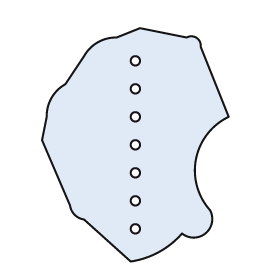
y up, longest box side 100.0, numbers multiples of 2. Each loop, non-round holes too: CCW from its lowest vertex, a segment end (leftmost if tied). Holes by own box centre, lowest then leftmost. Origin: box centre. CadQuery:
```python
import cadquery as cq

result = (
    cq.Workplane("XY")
    .moveTo(-2.0, -50.0)
    .threePointArc((10.0, -46.0), (20.0, -38.0))
    .threePointArc((30.0, -38.0), (32.0, -28.0))
    .threePointArc((26.0, -6.0), (40.0, 12.0))
    .lineTo(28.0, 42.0)
    .threePointArc((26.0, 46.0), (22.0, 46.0))
    .lineTo(2.0, 50.0)
    .lineTo(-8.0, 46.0)
    .threePointArc((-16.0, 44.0), (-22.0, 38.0))
    .lineTo(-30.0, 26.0)
    .threePointArc((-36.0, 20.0), (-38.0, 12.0))
    .lineTo(-40.0, 2.0)
    .lineTo(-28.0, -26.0)
    .threePointArc((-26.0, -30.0), (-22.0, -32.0))
    .close()
    .moveTo(0.0, -36.0)
    .circle(2.0)
    .moveTo(0.0, -24.0)
    .circle(2.0)
    .moveTo(0.0, -12.0)
    .circle(2.0)
    .moveTo(0.0, 0.0)
    .circle(2.0)
    .moveTo(0.0, 12.0)
    .circle(2.0)
    .moveTo(0.0, 24.0)
    .circle(2.0)
    .moveTo(0.0, 36.0)
    .circle(2.0)
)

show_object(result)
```